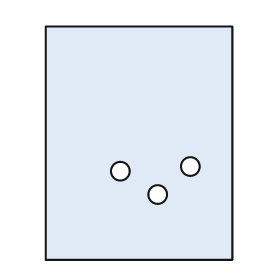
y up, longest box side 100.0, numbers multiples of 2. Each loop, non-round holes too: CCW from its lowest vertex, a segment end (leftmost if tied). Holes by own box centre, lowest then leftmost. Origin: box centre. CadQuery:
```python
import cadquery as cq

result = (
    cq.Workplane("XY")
    .moveTo(-40.0, -50.0)
    .lineTo(40.0, -50.0)
    .lineTo(40.0, 50.0)
    .lineTo(-40.0, 50.0)
    .close()
    .moveTo(8.0, -22.0)
    .circle(4.0)
    .moveTo(-8.0, -12.0)
    .circle(4.0)
    .moveTo(22.0, -10.0)
    .circle(4.0)
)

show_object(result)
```